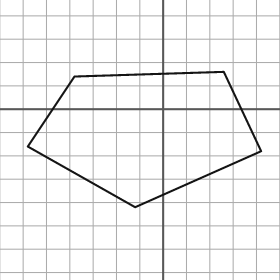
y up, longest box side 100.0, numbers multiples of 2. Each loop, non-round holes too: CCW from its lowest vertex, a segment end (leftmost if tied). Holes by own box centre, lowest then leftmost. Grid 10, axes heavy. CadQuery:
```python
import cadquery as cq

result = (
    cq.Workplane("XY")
    .moveTo(-12.0, -42.0)
    .lineTo(42.0, -18.0)
    .lineTo(26.0, 16.0)
    .lineTo(-38.0, 14.0)
    .lineTo(-58.0, -16.0)
    .close()
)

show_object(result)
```